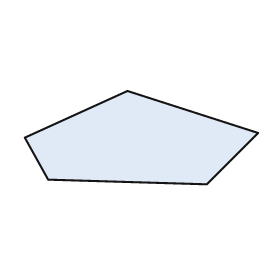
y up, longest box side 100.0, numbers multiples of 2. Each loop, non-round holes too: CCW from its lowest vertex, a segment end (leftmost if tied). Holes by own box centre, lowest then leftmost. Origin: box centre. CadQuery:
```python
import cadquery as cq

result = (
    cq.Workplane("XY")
    .moveTo(28.0, -20.0)
    .lineTo(50.0, 2.0)
    .lineTo(-6.0, 20.0)
    .lineTo(-50.0, 0.0)
    .lineTo(-40.0, -18.0)
    .close()
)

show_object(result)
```